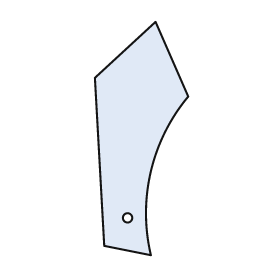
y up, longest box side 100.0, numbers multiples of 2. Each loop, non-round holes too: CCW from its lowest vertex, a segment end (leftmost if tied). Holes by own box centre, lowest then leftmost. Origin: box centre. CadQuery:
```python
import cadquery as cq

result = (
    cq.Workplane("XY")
    .moveTo(4.0, -50.0)
    .threePointArc((4.0, -14.0), (20.0, 18.0))
    .lineTo(6.0, 50.0)
    .lineTo(-20.0, 26.0)
    .lineTo(-16.0, -46.0)
    .close()
    .moveTo(-6.0, -34.0)
    .circle(2.0)
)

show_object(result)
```